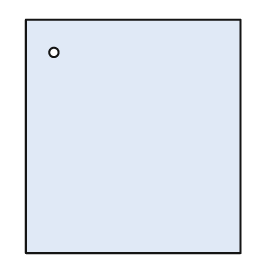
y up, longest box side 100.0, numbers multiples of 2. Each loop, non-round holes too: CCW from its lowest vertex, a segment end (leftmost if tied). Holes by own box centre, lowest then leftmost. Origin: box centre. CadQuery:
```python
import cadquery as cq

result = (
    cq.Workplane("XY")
    .moveTo(-46.0, -50.0)
    .lineTo(46.0, -50.0)
    .lineTo(46.0, 50.0)
    .lineTo(-46.0, 50.0)
    .close()
    .moveTo(-34.0, 36.0)
    .circle(2.0)
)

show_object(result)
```